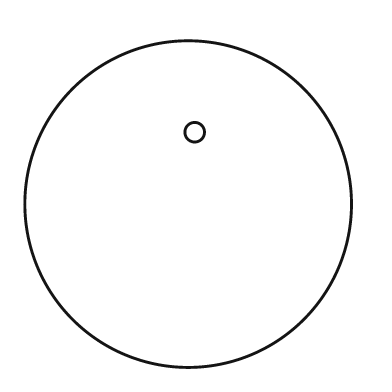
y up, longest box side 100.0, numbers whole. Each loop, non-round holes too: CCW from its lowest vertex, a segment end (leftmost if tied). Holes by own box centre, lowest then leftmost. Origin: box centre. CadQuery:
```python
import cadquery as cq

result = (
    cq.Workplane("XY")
    .moveTo(0.0, 0.0)
    .circle(50.0)
    .moveTo(2.0, 22.0)
    .circle(3.0)
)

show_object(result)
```